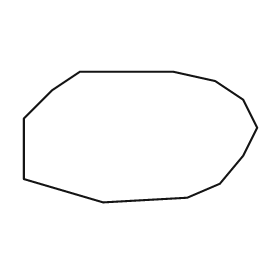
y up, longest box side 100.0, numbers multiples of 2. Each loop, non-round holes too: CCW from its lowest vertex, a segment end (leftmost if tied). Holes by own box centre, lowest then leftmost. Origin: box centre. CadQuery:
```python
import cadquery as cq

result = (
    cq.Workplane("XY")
    .moveTo(-16.0, -28.0)
    .lineTo(20.0, -26.0)
    .lineTo(34.0, -20.0)
    .lineTo(44.0, -8.0)
    .lineTo(50.0, 4.0)
    .lineTo(44.0, 16.0)
    .lineTo(32.0, 24.0)
    .lineTo(14.0, 28.0)
    .lineTo(-26.0, 28.0)
    .lineTo(-38.0, 20.0)
    .lineTo(-50.0, 8.0)
    .lineTo(-50.0, -18.0)
    .close()
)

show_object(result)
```